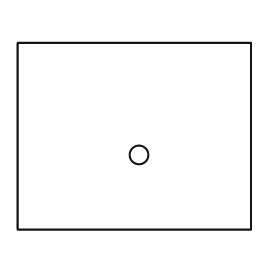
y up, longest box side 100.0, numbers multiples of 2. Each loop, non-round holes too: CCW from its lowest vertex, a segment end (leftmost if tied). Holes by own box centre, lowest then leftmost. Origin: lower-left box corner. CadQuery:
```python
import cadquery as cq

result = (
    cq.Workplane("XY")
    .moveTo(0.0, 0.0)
    .lineTo(100.0, 0.0)
    .lineTo(100.0, 80.0)
    .lineTo(0.0, 80.0)
    .close()
    .moveTo(52.0, 32.0)
    .circle(4.0)
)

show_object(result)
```